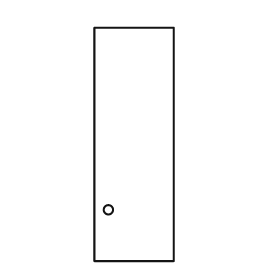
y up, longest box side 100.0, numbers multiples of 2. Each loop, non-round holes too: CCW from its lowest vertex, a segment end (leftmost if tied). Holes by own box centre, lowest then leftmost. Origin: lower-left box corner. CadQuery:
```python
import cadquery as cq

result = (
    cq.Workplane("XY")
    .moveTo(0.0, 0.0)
    .lineTo(34.0, 0.0)
    .lineTo(34.0, 100.0)
    .lineTo(0.0, 100.0)
    .close()
    .moveTo(6.0, 22.0)
    .circle(2.0)
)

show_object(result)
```